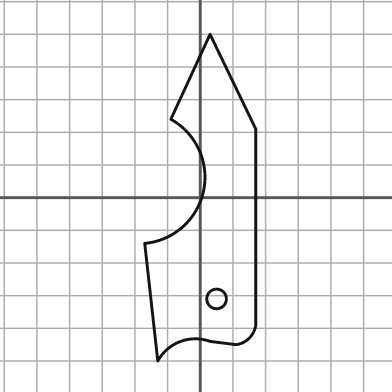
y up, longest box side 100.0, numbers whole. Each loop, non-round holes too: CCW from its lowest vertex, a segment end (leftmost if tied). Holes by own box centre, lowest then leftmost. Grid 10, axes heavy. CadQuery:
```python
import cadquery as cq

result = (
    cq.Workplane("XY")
    .moveTo(-13.0, -50.0)
    .threePointArc((-6.0, -44.0), (3.0, -44.0))
    .lineTo(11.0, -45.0)
    .threePointArc((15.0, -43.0), (17.0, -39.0))
    .lineTo(17.0, 21.0)
    .lineTo(3.0, 50.0)
    .lineTo(-9.0, 24.0)
    .threePointArc((1.0, 2.0), (-17.0, -14.0))
    .close()
    .moveTo(5.0, -31.0)
    .circle(3.0)
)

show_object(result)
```